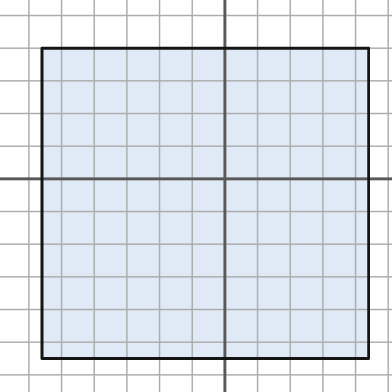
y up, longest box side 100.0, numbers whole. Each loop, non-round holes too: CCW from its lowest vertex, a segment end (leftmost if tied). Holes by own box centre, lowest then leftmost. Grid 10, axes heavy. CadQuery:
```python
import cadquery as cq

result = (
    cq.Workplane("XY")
    .moveTo(-56.0, -55.0)
    .lineTo(44.0, -55.0)
    .lineTo(44.0, 40.0)
    .lineTo(-56.0, 40.0)
    .close()
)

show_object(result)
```